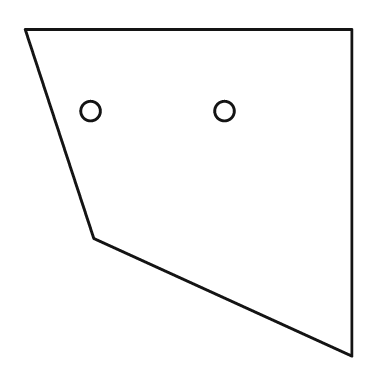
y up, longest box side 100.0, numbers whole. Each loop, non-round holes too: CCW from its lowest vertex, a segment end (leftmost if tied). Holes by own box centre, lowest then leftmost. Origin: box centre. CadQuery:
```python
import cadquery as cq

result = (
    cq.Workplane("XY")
    .moveTo(50.0, -50.0)
    .lineTo(50.0, 50.0)
    .lineTo(-50.0, 50.0)
    .lineTo(-29.0, -14.0)
    .close()
    .moveTo(-30.0, 25.0)
    .circle(3.0)
    .moveTo(11.0, 25.0)
    .circle(3.0)
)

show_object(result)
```